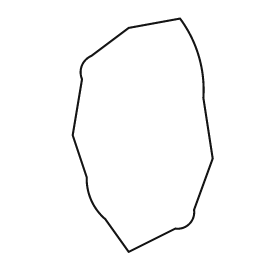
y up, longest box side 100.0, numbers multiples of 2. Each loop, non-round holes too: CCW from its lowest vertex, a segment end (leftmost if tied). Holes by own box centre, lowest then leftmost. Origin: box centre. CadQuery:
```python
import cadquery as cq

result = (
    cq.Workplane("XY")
    .moveTo(-6.0, -50.0)
    .lineTo(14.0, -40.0)
    .threePointArc((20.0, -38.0), (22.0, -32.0))
    .lineTo(30.0, -10.0)
    .lineTo(26.0, 16.0)
    .threePointArc((24.0, 34.0), (16.0, 50.0))
    .lineTo(-6.0, 46.0)
    .lineTo(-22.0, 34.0)
    .threePointArc((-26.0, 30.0), (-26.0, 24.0))
    .lineTo(-30.0, 0.0)
    .lineTo(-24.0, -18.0)
    .threePointArc((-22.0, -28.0), (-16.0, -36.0))
    .close()
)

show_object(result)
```